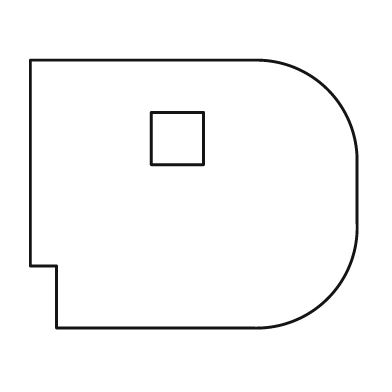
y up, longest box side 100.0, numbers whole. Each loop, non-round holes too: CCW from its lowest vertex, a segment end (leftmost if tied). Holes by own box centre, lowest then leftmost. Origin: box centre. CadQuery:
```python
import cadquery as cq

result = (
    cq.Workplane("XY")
    .moveTo(-42.0, -41.0)
    .lineTo(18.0, -41.0)
    .threePointArc((41.0, -32.0), (50.0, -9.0))
    .lineTo(50.0, 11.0)
    .threePointArc((41.0, 32.0), (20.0, 41.0))
    .lineTo(-50.0, 41.0)
    .lineTo(-50.0, -22.0)
    .lineTo(-42.0, -22.0)
    .close()
    .moveTo(-13.0, 9.0)
    .lineTo(3.0, 9.0)
    .lineTo(3.0, 25.0)
    .lineTo(-13.0, 25.0)
    .close()
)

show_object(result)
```